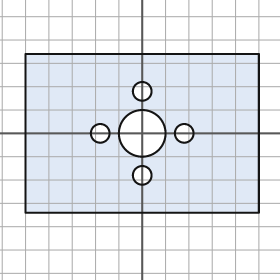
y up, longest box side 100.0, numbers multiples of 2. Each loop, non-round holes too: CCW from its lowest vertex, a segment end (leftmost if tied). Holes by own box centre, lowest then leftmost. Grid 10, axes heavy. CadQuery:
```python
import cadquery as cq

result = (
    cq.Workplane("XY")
    .moveTo(-50.0, -34.0)
    .lineTo(50.0, -34.0)
    .lineTo(50.0, 34.0)
    .lineTo(-50.0, 34.0)
    .close()
    .moveTo(0.0, -18.0)
    .circle(4.0)
    .moveTo(-18.0, 0.0)
    .circle(4.0)
    .moveTo(0.0, 0.0)
    .circle(10.0)
    .moveTo(18.0, 0.0)
    .circle(4.0)
    .moveTo(0.0, 18.0)
    .circle(4.0)
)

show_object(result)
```